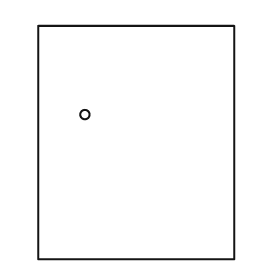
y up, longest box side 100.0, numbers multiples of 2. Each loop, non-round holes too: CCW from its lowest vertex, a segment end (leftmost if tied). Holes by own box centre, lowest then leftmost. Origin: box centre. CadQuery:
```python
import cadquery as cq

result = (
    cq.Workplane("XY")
    .moveTo(-42.0, -50.0)
    .lineTo(42.0, -50.0)
    .lineTo(42.0, 50.0)
    .lineTo(-42.0, 50.0)
    .close()
    .moveTo(-22.0, 12.0)
    .circle(2.0)
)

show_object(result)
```